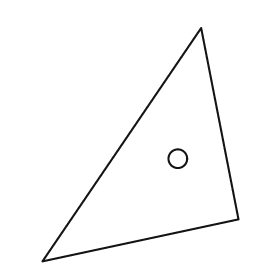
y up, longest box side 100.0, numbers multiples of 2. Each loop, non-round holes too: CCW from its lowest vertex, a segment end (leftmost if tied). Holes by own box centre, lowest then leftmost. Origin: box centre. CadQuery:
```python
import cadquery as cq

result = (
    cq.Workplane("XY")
    .moveTo(-42.0, -50.0)
    .lineTo(42.0, -32.0)
    .lineTo(26.0, 50.0)
    .close()
    .moveTo(16.0, -6.0)
    .circle(4.0)
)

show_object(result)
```